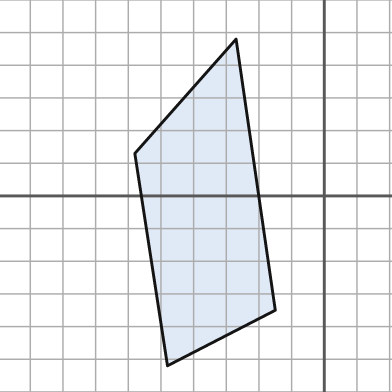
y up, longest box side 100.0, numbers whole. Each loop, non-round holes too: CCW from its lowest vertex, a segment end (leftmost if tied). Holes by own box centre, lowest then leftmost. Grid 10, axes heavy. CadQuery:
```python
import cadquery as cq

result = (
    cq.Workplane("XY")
    .moveTo(-48.0, -52.0)
    .lineTo(-15.0, -35.0)
    .lineTo(-27.0, 48.0)
    .lineTo(-58.0, 13.0)
    .close()
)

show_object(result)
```